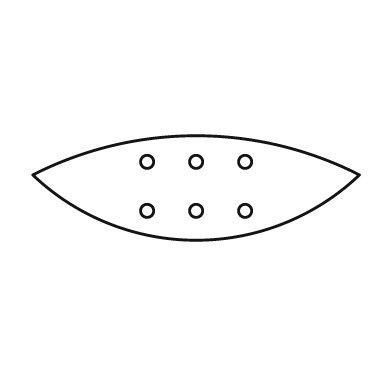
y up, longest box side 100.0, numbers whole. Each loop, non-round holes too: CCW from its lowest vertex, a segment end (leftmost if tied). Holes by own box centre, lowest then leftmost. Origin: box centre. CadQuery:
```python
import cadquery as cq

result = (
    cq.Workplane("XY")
    .moveTo(-50.0, 4.0)
    .threePointArc((0.0, -16.0), (50.0, 4.0))
    .threePointArc((0.0, 16.0), (-50.0, 4.0))
    .close()
    .moveTo(-15.0, -7.0)
    .circle(2.0)
    .moveTo(0.0, -7.0)
    .circle(2.0)
    .moveTo(15.0, -7.0)
    .circle(2.0)
    .moveTo(-15.0, 8.0)
    .circle(2.0)
    .moveTo(0.0, 8.0)
    .circle(2.0)
    .moveTo(15.0, 8.0)
    .circle(2.0)
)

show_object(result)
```